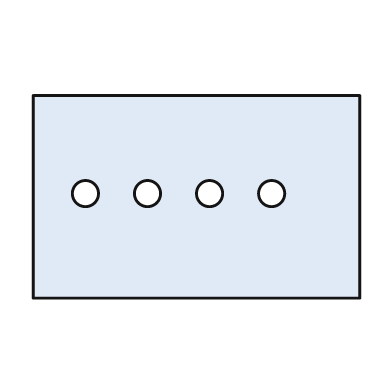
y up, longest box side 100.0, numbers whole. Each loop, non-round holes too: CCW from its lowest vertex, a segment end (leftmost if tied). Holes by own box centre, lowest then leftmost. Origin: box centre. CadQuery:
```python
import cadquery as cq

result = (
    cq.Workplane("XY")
    .moveTo(-50.0, -31.0)
    .lineTo(50.0, -31.0)
    .lineTo(50.0, 31.0)
    .lineTo(-50.0, 31.0)
    .close()
    .moveTo(-34.0, 1.0)
    .circle(4.0)
    .moveTo(-15.0, 1.0)
    .circle(4.0)
    .moveTo(4.0, 1.0)
    .circle(4.0)
    .moveTo(23.0, 1.0)
    .circle(4.0)
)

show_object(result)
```